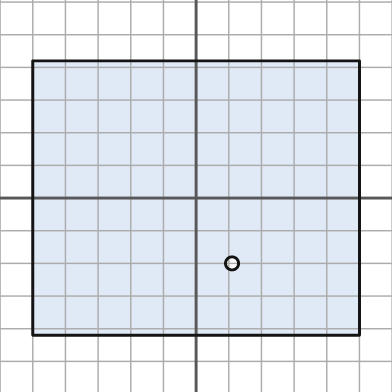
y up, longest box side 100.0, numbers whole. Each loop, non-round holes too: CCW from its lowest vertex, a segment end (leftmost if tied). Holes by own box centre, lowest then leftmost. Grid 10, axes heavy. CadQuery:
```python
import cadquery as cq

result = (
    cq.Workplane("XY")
    .moveTo(-50.0, -42.0)
    .lineTo(50.0, -42.0)
    .lineTo(50.0, 42.0)
    .lineTo(-50.0, 42.0)
    .close()
    .moveTo(11.0, -20.0)
    .circle(2.0)
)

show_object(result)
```